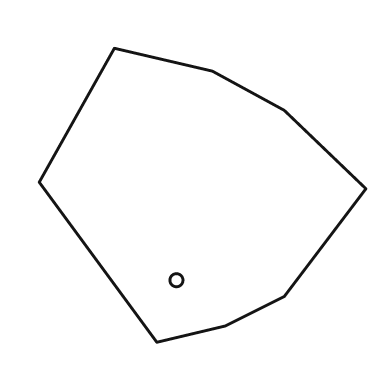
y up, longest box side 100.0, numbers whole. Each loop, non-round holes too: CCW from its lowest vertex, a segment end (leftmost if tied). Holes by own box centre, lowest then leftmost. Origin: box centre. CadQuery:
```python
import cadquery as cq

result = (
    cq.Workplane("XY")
    .moveTo(-14.0, -45.0)
    .lineTo(7.0, -40.0)
    .lineTo(25.0, -31.0)
    .lineTo(50.0, 2.0)
    .lineTo(25.0, 26.0)
    .lineTo(3.0, 38.0)
    .lineTo(-27.0, 45.0)
    .lineTo(-50.0, 4.0)
    .close()
    .moveTo(-8.0, -26.0)
    .circle(2.0)
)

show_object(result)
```